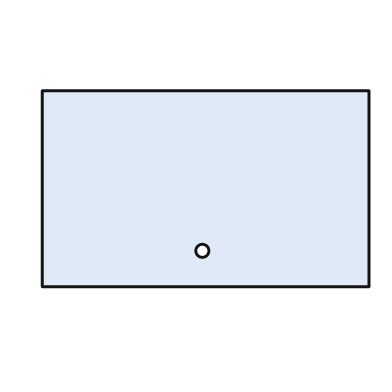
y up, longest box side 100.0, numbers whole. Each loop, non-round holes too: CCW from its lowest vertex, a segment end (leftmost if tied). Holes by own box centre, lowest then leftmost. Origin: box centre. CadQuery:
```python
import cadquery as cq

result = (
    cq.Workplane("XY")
    .moveTo(-50.0, -30.0)
    .lineTo(50.0, -30.0)
    .lineTo(50.0, 30.0)
    .lineTo(-50.0, 30.0)
    .close()
    .moveTo(-1.0, -19.0)
    .circle(2.0)
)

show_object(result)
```